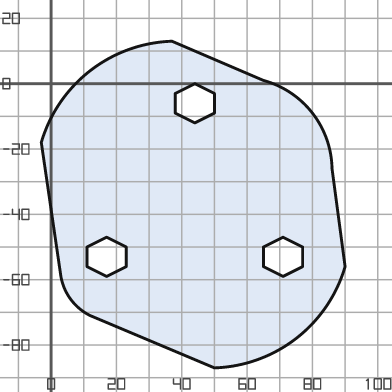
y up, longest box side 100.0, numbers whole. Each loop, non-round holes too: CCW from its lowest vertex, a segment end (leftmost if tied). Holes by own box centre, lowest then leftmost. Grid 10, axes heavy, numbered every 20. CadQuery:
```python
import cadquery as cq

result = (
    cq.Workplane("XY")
    .moveTo(50.0, -87.0)
    .threePointArc((75.0, -78.0), (90.0, -56.0))
    .lineTo(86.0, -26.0)
    .threePointArc((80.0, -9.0), (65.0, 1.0))
    .lineTo(37.0, 13.0)
    .threePointArc((12.0, 4.0), (-3.0, -18.0))
    .lineTo(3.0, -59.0)
    .threePointArc((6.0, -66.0), (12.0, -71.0))
    .close()
    .moveTo(17.0, -59.0)
    .lineTo(23.0, -56.0)
    .lineTo(23.0, -50.0)
    .lineTo(17.0, -47.0)
    .lineTo(11.0, -50.0)
    .lineTo(11.0, -56.0)
    .close()
    .moveTo(71.0, -59.0)
    .lineTo(77.0, -56.0)
    .lineTo(77.0, -50.0)
    .lineTo(71.0, -47.0)
    .lineTo(65.0, -50.0)
    .lineTo(65.0, -56.0)
    .close()
    .moveTo(44.0, -12.0)
    .lineTo(50.0, -9.0)
    .lineTo(50.0, -3.0)
    .lineTo(44.0, 0.0)
    .lineTo(38.0, -3.0)
    .lineTo(38.0, -9.0)
    .close()
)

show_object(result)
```